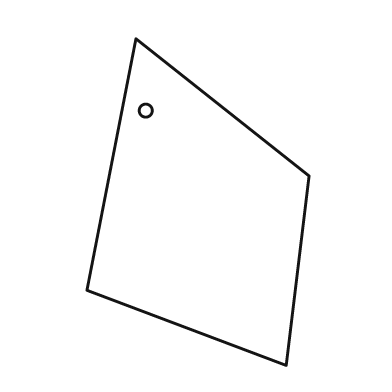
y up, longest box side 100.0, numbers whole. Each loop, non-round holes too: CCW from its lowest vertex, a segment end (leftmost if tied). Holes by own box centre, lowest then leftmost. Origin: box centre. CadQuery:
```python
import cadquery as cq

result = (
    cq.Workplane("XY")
    .moveTo(27.0, -50.0)
    .lineTo(34.0, 8.0)
    .lineTo(-19.0, 50.0)
    .lineTo(-34.0, -27.0)
    .close()
    .moveTo(-16.0, 28.0)
    .circle(2.0)
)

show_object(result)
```